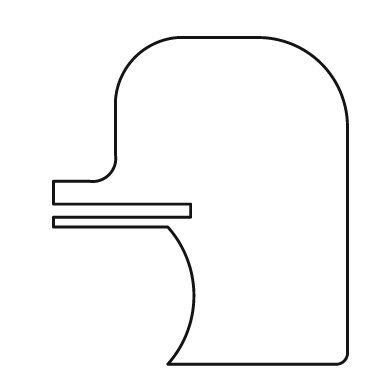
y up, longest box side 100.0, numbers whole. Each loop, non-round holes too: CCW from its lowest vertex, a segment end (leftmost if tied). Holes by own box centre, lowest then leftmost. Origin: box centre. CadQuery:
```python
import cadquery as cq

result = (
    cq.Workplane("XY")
    .moveTo(-10.0, -50.0)
    .lineTo(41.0, -50.0)
    .threePointArc((44.0, -49.0), (45.0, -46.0))
    .lineTo(45.0, 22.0)
    .threePointArc((37.0, 42.0), (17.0, 50.0))
    .lineTo(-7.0, 50.0)
    .threePointArc((-20.0, 44.0), (-26.0, 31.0))
    .lineTo(-26.0, 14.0)
    .threePointArc((-28.0, 8.0), (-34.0, 6.0))
    .lineTo(-45.0, 6.0)
    .lineTo(-45.0, -1.0)
    .lineTo(-3.0, -1.0)
    .lineTo(-3.0, -5.0)
    .lineTo(-45.0, -5.0)
    .lineTo(-45.0, -8.0)
    .lineTo(-10.0, -8.0)
    .threePointArc((-2.0, -29.0), (-10.0, -50.0))
    .close()
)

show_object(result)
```